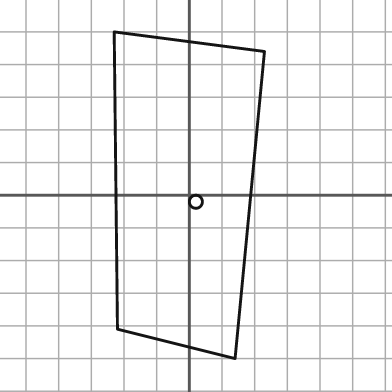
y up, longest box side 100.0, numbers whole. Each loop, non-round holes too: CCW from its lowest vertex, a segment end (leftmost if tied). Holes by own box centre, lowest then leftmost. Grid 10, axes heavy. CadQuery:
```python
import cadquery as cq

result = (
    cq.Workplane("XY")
    .moveTo(14.0, -50.0)
    .lineTo(23.0, 44.0)
    .lineTo(-23.0, 50.0)
    .lineTo(-22.0, -41.0)
    .close()
    .moveTo(2.0, -2.0)
    .circle(2.0)
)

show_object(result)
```